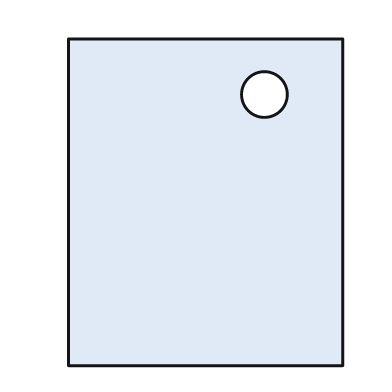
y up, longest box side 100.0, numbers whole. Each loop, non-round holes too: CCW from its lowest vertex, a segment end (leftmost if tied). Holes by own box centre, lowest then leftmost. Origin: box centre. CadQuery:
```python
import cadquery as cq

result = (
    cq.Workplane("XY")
    .moveTo(-42.0, -50.0)
    .lineTo(42.0, -50.0)
    .lineTo(42.0, 50.0)
    .lineTo(-42.0, 50.0)
    .close()
    .moveTo(18.0, 33.0)
    .circle(7.0)
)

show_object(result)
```